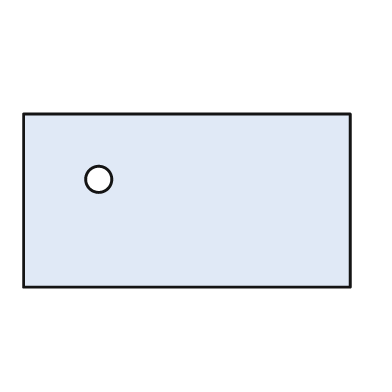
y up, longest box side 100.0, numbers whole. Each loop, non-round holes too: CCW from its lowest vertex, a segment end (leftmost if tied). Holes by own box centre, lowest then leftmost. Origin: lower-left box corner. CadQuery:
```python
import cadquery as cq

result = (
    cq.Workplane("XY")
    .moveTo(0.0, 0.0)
    .lineTo(100.0, 0.0)
    .lineTo(100.0, 53.0)
    .lineTo(0.0, 53.0)
    .close()
    .moveTo(23.0, 33.0)
    .circle(4.0)
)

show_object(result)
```